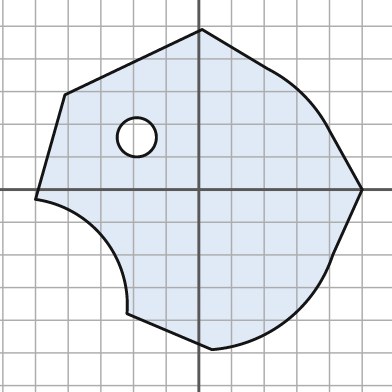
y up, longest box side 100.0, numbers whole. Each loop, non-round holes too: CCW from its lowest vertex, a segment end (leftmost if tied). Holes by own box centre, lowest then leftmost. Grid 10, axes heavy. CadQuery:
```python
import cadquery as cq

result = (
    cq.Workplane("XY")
    .moveTo(4.0, -49.0)
    .threePointArc((27.0, -40.0), (41.0, -20.0))
    .lineTo(50.0, 0.0)
    .lineTo(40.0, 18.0)
    .threePointArc((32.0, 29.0), (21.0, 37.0))
    .lineTo(1.0, 49.0)
    .lineTo(-41.0, 29.0)
    .lineTo(-50.0, -3.0)
    .threePointArc((-29.0, -15.0), (-22.0, -38.0))
    .close()
    .moveTo(-19.0, 16.0)
    .circle(6.0)
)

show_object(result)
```